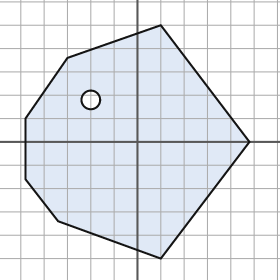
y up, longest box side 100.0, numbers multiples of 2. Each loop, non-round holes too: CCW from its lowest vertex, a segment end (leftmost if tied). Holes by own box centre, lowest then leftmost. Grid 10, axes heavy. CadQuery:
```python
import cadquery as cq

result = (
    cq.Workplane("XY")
    .moveTo(10.0, -50.0)
    .lineTo(48.0, 0.0)
    .lineTo(10.0, 50.0)
    .lineTo(-30.0, 36.0)
    .lineTo(-48.0, 10.0)
    .lineTo(-48.0, -16.0)
    .lineTo(-34.0, -34.0)
    .close()
    .moveTo(-20.0, 18.0)
    .circle(4.0)
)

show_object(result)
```